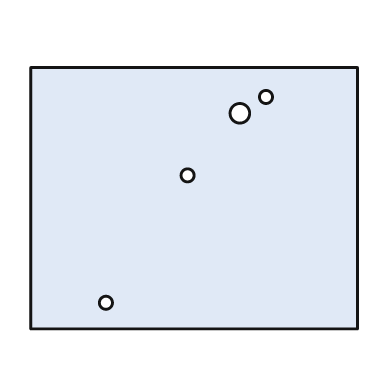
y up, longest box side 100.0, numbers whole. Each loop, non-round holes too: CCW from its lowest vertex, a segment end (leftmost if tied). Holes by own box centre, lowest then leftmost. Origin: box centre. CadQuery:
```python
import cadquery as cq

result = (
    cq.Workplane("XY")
    .moveTo(-50.0, -40.0)
    .lineTo(50.0, -40.0)
    .lineTo(50.0, 40.0)
    .lineTo(-50.0, 40.0)
    .close()
    .moveTo(-27.0, -32.0)
    .circle(2.0)
    .moveTo(-2.0, 7.0)
    .circle(2.0)
    .moveTo(14.0, 26.0)
    .circle(3.0)
    .moveTo(22.0, 31.0)
    .circle(2.0)
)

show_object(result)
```